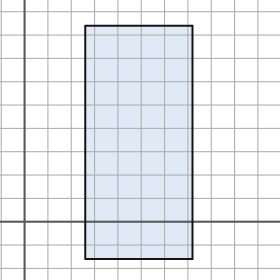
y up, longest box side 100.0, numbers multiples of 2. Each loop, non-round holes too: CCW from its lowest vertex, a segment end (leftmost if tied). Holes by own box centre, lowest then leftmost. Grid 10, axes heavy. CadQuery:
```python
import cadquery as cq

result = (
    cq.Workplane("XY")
    .moveTo(26.0, -16.0)
    .lineTo(72.0, -16.0)
    .lineTo(72.0, 84.0)
    .lineTo(26.0, 84.0)
    .close()
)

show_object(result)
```